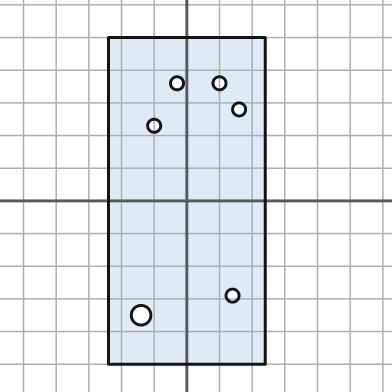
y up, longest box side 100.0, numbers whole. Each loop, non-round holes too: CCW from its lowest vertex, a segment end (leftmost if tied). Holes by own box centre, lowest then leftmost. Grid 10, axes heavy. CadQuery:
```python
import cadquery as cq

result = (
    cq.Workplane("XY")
    .moveTo(-24.0, -50.0)
    .lineTo(24.0, -50.0)
    .lineTo(24.0, 50.0)
    .lineTo(-24.0, 50.0)
    .close()
    .moveTo(-14.0, -35.0)
    .circle(3.0)
    .moveTo(14.0, -29.0)
    .circle(2.0)
    .moveTo(-10.0, 23.0)
    .circle(2.0)
    .moveTo(16.0, 28.0)
    .circle(2.0)
    .moveTo(-3.0, 36.0)
    .circle(2.0)
    .moveTo(10.0, 36.0)
    .circle(2.0)
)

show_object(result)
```